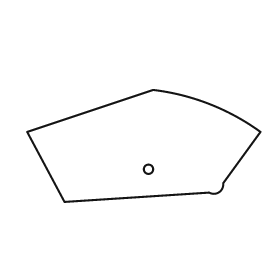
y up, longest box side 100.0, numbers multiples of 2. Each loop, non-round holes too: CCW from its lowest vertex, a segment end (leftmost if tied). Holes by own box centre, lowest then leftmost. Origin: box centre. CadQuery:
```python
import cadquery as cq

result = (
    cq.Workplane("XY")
    .moveTo(-34.0, -24.0)
    .lineTo(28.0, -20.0)
    .threePointArc((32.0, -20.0), (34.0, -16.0))
    .lineTo(50.0, 6.0)
    .threePointArc((28.0, 18.0), (4.0, 24.0))
    .lineTo(-50.0, 6.0)
    .close()
    .moveTo(2.0, -10.0)
    .circle(2.0)
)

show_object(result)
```